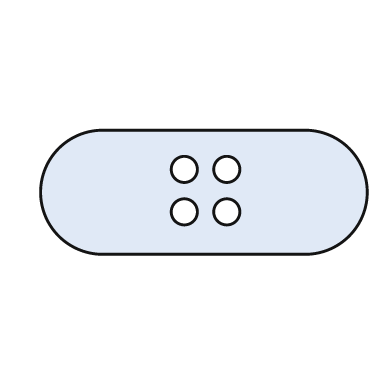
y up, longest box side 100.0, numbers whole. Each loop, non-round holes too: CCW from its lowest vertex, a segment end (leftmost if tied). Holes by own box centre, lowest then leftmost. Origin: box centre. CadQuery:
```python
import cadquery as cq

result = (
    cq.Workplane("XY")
    .moveTo(-31.0, -19.0)
    .lineTo(31.0, -19.0)
    .threePointArc((50.0, 0.0), (31.0, 19.0))
    .lineTo(-31.0, 19.0)
    .threePointArc((-50.0, 0.0), (-31.0, -19.0))
    .close()
    .moveTo(-6.0, -6.0)
    .circle(4.0)
    .moveTo(7.0, -6.0)
    .circle(4.0)
    .moveTo(-6.0, 7.0)
    .circle(4.0)
    .moveTo(7.0, 7.0)
    .circle(4.0)
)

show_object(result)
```